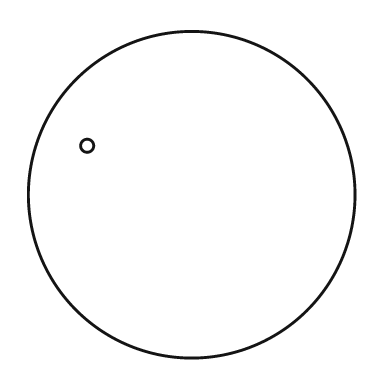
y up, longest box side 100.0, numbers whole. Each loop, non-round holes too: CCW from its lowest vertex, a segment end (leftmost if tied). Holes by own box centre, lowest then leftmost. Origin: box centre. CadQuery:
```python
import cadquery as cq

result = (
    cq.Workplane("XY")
    .moveTo(0.0, 0.0)
    .circle(50.0)
    .moveTo(-32.0, 15.0)
    .circle(2.0)
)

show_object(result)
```